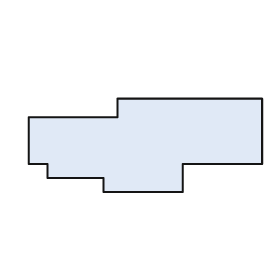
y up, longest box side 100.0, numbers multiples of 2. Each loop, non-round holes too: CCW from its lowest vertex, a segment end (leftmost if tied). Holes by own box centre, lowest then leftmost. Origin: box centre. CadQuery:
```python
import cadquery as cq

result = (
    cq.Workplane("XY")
    .moveTo(-18.0, -20.0)
    .lineTo(16.0, -20.0)
    .lineTo(16.0, -8.0)
    .lineTo(50.0, -8.0)
    .lineTo(50.0, 20.0)
    .lineTo(-12.0, 20.0)
    .lineTo(-12.0, 12.0)
    .lineTo(-50.0, 12.0)
    .lineTo(-50.0, -8.0)
    .lineTo(-42.0, -8.0)
    .lineTo(-42.0, -14.0)
    .lineTo(-18.0, -14.0)
    .close()
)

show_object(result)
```